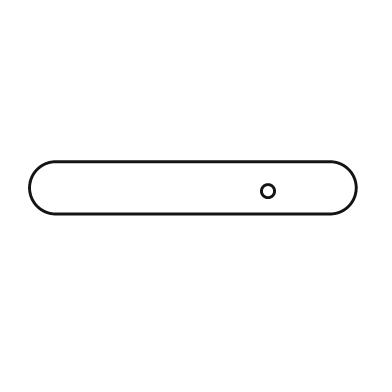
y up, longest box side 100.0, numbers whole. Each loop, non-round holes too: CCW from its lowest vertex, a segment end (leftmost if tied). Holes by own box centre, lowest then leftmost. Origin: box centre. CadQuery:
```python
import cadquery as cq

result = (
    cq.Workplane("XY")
    .moveTo(-42.0, -8.0)
    .lineTo(42.0, -8.0)
    .threePointArc((50.0, 0.0), (42.0, 8.0))
    .lineTo(-42.0, 8.0)
    .threePointArc((-50.0, 0.0), (-42.0, -8.0))
    .close()
    .moveTo(23.0, -1.0)
    .circle(2.0)
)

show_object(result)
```